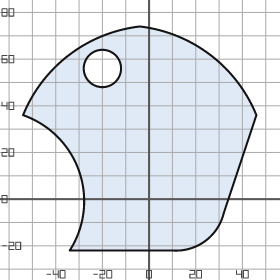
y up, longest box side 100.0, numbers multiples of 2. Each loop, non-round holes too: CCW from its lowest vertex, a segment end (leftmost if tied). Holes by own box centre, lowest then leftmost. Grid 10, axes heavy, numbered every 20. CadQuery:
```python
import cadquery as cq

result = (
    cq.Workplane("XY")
    .moveTo(-34.0, -22.0)
    .lineTo(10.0, -22.0)
    .threePointArc((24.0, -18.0), (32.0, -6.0))
    .lineTo(46.0, 36.0)
    .threePointArc((26.0, 62.0), (-4.0, 74.0))
    .threePointArc((-34.0, 62.0), (-54.0, 36.0))
    .threePointArc((-30.0, 12.0), (-34.0, -22.0))
    .close()
    .moveTo(-20.0, 56.0)
    .circle(8.0)
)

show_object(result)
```